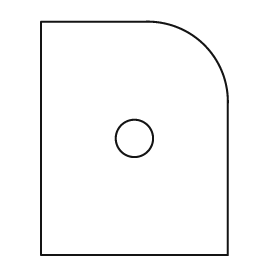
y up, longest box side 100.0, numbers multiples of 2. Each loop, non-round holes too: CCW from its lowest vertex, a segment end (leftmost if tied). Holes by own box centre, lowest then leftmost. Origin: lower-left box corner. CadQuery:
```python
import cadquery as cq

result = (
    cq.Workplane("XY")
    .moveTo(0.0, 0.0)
    .lineTo(80.0, 0.0)
    .lineTo(80.0, 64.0)
    .threePointArc((70.0, 90.0), (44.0, 100.0))
    .lineTo(0.0, 100.0)
    .close()
    .moveTo(40.0, 50.0)
    .circle(8.0)
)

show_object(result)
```